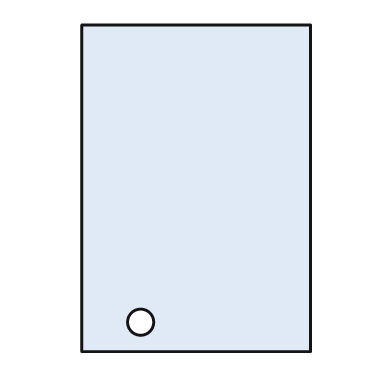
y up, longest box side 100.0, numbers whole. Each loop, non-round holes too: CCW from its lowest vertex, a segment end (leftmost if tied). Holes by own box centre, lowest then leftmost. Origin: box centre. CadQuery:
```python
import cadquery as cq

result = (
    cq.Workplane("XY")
    .moveTo(-35.0, -50.0)
    .lineTo(35.0, -50.0)
    .lineTo(35.0, 50.0)
    .lineTo(-35.0, 50.0)
    .close()
    .moveTo(-17.0, -41.0)
    .circle(4.0)
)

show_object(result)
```